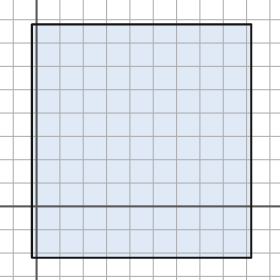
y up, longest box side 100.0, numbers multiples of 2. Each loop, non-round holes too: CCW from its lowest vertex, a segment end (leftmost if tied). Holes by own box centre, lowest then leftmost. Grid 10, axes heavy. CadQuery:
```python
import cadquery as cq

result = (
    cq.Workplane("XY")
    .moveTo(-2.0, -22.0)
    .lineTo(92.0, -22.0)
    .lineTo(92.0, 78.0)
    .lineTo(-2.0, 78.0)
    .close()
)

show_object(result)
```